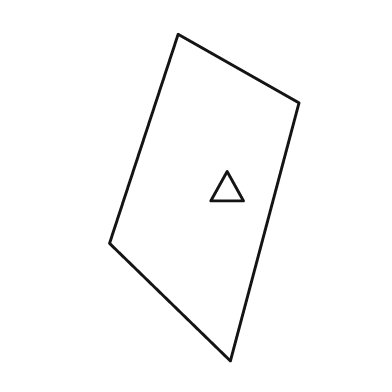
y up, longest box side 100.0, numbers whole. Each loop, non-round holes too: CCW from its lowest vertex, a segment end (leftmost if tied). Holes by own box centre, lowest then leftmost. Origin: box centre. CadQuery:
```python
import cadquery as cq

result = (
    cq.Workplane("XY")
    .moveTo(8.0, -50.0)
    .lineTo(29.0, 29.0)
    .lineTo(-8.0, 50.0)
    .lineTo(-29.0, -14.0)
    .close()
    .moveTo(2.0, -1.0)
    .lineTo(12.0, -1.0)
    .lineTo(7.0, 8.0)
    .close()
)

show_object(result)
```